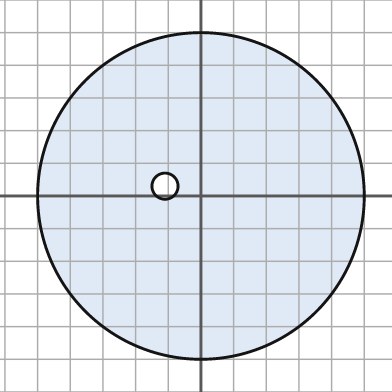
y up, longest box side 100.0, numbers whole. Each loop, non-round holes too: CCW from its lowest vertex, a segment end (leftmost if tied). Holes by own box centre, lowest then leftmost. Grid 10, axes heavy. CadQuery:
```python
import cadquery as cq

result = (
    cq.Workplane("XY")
    .moveTo(0.0, 0.0)
    .circle(50.0)
    .moveTo(-11.0, 3.0)
    .circle(4.0)
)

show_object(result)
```